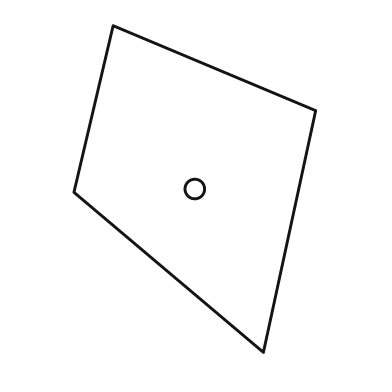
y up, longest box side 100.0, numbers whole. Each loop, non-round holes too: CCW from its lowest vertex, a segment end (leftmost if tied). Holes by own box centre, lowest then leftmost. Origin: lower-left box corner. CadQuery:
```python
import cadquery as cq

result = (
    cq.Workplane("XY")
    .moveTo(58.0, 0.0)
    .lineTo(74.0, 74.0)
    .lineTo(12.0, 100.0)
    .lineTo(0.0, 49.0)
    .close()
    .moveTo(37.0, 50.0)
    .circle(3.0)
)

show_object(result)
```